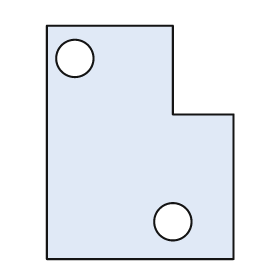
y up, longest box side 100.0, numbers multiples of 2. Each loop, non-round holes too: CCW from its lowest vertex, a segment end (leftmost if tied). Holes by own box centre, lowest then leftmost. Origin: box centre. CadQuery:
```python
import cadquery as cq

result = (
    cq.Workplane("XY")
    .moveTo(-40.0, -50.0)
    .lineTo(40.0, -50.0)
    .lineTo(40.0, 12.0)
    .lineTo(14.0, 12.0)
    .lineTo(14.0, 50.0)
    .lineTo(-40.0, 50.0)
    .close()
    .moveTo(14.0, -34.0)
    .circle(8.0)
    .moveTo(-28.0, 36.0)
    .circle(8.0)
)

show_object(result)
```